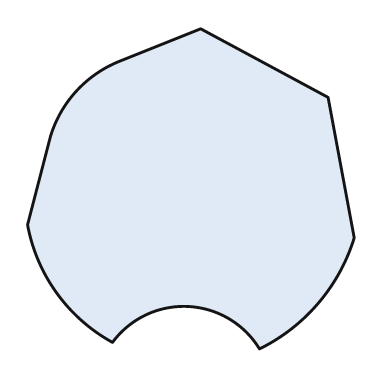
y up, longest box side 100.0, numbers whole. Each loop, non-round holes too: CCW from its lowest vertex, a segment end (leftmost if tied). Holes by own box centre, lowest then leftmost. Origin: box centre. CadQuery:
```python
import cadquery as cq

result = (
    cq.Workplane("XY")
    .moveTo(21.0, -49.0)
    .threePointArc((39.0, -35.0), (50.0, -15.0))
    .lineTo(42.0, 28.0)
    .lineTo(3.0, 49.0)
    .lineTo(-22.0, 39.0)
    .threePointArc((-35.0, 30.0), (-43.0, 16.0))
    .lineTo(-50.0, -11.0)
    .threePointArc((-41.0, -32.0), (-24.0, -47.0))
    .threePointArc((-1.0, -36.0), (21.0, -49.0))
    .close()
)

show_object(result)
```